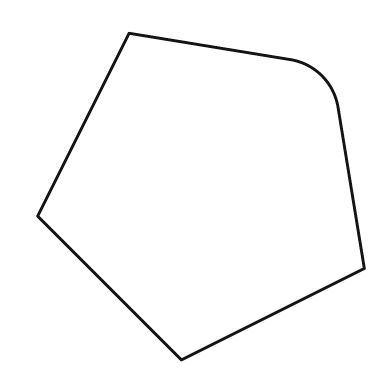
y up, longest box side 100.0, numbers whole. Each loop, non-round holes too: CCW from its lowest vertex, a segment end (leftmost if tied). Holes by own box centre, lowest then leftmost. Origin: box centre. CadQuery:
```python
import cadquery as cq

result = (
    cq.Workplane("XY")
    .moveTo(-6.0, -50.0)
    .lineTo(50.0, -22.0)
    .lineTo(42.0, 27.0)
    .threePointArc((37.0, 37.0), (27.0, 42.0))
    .lineTo(-22.0, 50.0)
    .lineTo(-50.0, -6.0)
    .close()
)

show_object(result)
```